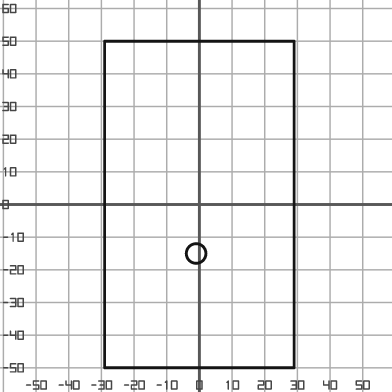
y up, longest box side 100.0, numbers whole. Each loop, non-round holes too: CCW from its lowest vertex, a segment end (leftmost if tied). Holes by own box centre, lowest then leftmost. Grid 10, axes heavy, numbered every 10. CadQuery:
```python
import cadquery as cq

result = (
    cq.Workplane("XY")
    .moveTo(-29.0, -50.0)
    .lineTo(29.0, -50.0)
    .lineTo(29.0, 50.0)
    .lineTo(-29.0, 50.0)
    .close()
    .moveTo(-1.0, -15.0)
    .circle(3.0)
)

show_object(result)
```